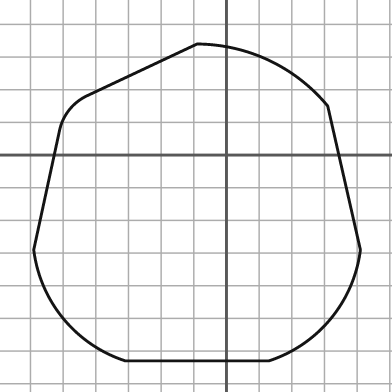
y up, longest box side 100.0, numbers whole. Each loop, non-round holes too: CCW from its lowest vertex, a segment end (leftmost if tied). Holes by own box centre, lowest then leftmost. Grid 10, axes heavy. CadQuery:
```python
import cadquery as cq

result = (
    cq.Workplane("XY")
    .moveTo(-31.0, -63.0)
    .lineTo(13.0, -63.0)
    .threePointArc((32.0, -50.0), (41.0, -29.0))
    .lineTo(31.0, 15.0)
    .threePointArc((13.0, 29.0), (-9.0, 34.0))
    .lineTo(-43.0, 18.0)
    .threePointArc((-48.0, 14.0), (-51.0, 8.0))
    .lineTo(-59.0, -29.0)
    .threePointArc((-50.0, -50.0), (-31.0, -63.0))
    .close()
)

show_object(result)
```